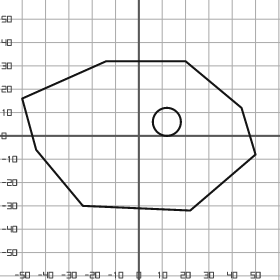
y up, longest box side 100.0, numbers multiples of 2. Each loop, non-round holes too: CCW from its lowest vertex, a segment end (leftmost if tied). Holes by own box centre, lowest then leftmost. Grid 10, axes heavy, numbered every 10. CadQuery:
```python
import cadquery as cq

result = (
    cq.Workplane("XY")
    .moveTo(22.0, -32.0)
    .lineTo(50.0, -8.0)
    .lineTo(44.0, 12.0)
    .lineTo(20.0, 32.0)
    .lineTo(-14.0, 32.0)
    .lineTo(-50.0, 16.0)
    .lineTo(-44.0, -6.0)
    .lineTo(-24.0, -30.0)
    .close()
    .moveTo(12.0, 6.0)
    .circle(6.0)
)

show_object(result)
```